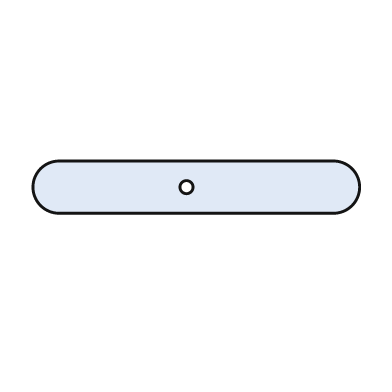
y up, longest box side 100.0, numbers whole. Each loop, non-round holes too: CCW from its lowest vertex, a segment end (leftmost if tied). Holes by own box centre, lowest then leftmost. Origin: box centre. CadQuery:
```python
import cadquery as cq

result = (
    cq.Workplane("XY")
    .moveTo(-42.0, -8.0)
    .lineTo(42.0, -8.0)
    .threePointArc((50.0, 0.0), (42.0, 8.0))
    .lineTo(-42.0, 8.0)
    .threePointArc((-50.0, 0.0), (-42.0, -8.0))
    .close()
    .moveTo(-3.0, 0.0)
    .circle(2.0)
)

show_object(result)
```